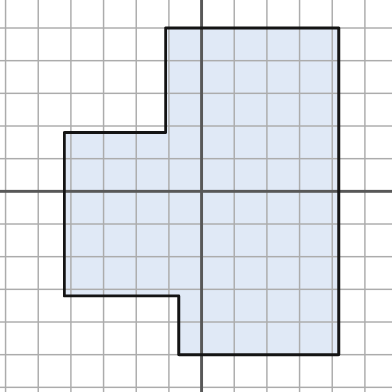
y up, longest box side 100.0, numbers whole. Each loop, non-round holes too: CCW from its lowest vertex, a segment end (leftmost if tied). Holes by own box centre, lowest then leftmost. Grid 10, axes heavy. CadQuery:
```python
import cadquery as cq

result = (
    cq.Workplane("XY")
    .moveTo(-7.0, -50.0)
    .lineTo(42.0, -50.0)
    .lineTo(42.0, 50.0)
    .lineTo(-11.0, 50.0)
    .lineTo(-11.0, 18.0)
    .lineTo(-42.0, 18.0)
    .lineTo(-42.0, -32.0)
    .lineTo(-7.0, -32.0)
    .close()
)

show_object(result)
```